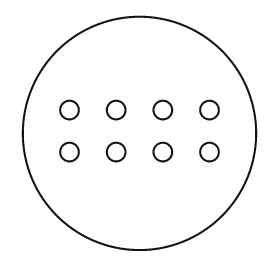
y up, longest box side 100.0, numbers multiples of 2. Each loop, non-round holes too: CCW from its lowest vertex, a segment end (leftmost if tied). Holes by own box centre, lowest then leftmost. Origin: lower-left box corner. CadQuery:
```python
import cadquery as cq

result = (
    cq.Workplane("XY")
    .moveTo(50.0, 50.0)
    .circle(50.0)
    .moveTo(20.0, 42.0)
    .circle(4.0)
    .moveTo(40.0, 42.0)
    .circle(4.0)
    .moveTo(60.0, 42.0)
    .circle(4.0)
    .moveTo(80.0, 42.0)
    .circle(4.0)
    .moveTo(20.0, 60.0)
    .circle(4.0)
    .moveTo(40.0, 60.0)
    .circle(4.0)
    .moveTo(60.0, 60.0)
    .circle(4.0)
    .moveTo(80.0, 60.0)
    .circle(4.0)
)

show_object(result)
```